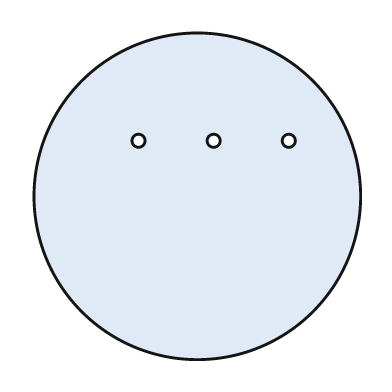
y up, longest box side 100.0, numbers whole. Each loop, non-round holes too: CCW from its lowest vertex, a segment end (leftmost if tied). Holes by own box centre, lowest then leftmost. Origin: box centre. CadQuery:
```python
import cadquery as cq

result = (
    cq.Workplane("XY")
    .moveTo(0.0, 0.0)
    .circle(50.0)
    .moveTo(-18.0, 17.0)
    .circle(2.0)
    .moveTo(5.0, 17.0)
    .circle(2.0)
    .moveTo(28.0, 17.0)
    .circle(2.0)
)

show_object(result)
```